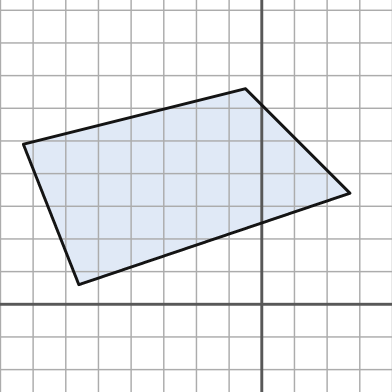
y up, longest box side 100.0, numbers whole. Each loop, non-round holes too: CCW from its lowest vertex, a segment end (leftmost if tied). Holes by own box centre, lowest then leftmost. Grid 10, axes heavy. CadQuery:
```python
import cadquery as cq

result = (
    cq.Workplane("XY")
    .moveTo(-56.0, 6.0)
    .lineTo(27.0, 34.0)
    .lineTo(-5.0, 66.0)
    .lineTo(-73.0, 49.0)
    .close()
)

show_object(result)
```